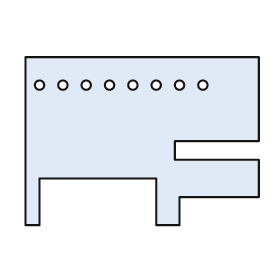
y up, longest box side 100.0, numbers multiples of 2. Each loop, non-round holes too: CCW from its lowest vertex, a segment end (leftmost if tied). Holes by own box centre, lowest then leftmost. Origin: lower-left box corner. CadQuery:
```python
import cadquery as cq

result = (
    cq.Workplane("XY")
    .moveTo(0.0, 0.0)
    .lineTo(6.0, 0.0)
    .lineTo(6.0, 20.0)
    .lineTo(56.0, 20.0)
    .lineTo(56.0, 0.0)
    .lineTo(66.0, 0.0)
    .lineTo(66.0, 12.0)
    .lineTo(100.0, 12.0)
    .lineTo(100.0, 28.0)
    .lineTo(64.0, 28.0)
    .lineTo(64.0, 36.0)
    .lineTo(100.0, 36.0)
    .lineTo(100.0, 72.0)
    .lineTo(0.0, 72.0)
    .close()
    .moveTo(6.0, 60.0)
    .circle(2.0)
    .moveTo(16.0, 60.0)
    .circle(2.0)
    .moveTo(26.0, 60.0)
    .circle(2.0)
    .moveTo(36.0, 60.0)
    .circle(2.0)
    .moveTo(46.0, 60.0)
    .circle(2.0)
    .moveTo(56.0, 60.0)
    .circle(2.0)
    .moveTo(66.0, 60.0)
    .circle(2.0)
    .moveTo(76.0, 60.0)
    .circle(2.0)
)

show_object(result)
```